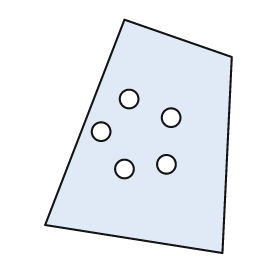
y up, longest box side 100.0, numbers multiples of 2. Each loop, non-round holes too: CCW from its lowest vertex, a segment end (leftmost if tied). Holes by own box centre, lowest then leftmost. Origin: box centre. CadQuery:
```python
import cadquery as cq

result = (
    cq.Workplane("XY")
    .moveTo(36.0, -50.0)
    .lineTo(40.0, 34.0)
    .lineTo(-6.0, 50.0)
    .lineTo(-40.0, -38.0)
    .close()
    .moveTo(-6.0, -14.0)
    .circle(4.0)
    .moveTo(12.0, -12.0)
    .circle(4.0)
    .moveTo(-16.0, 2.0)
    .circle(4.0)
    .moveTo(14.0, 8.0)
    .circle(4.0)
    .moveTo(-4.0, 16.0)
    .circle(4.0)
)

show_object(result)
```